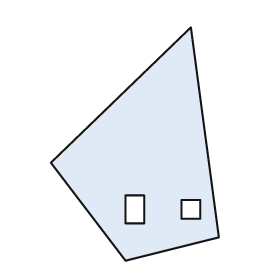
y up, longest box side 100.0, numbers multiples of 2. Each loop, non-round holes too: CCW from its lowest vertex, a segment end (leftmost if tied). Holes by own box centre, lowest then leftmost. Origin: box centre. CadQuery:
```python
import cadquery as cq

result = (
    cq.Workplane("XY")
    .moveTo(-4.0, -50.0)
    .lineTo(36.0, -40.0)
    .lineTo(24.0, 50.0)
    .lineTo(-36.0, -8.0)
    .close()
    .moveTo(-4.0, -34.0)
    .lineTo(4.0, -34.0)
    .lineTo(4.0, -22.0)
    .lineTo(-4.0, -22.0)
    .close()
    .moveTo(20.0, -32.0)
    .lineTo(28.0, -32.0)
    .lineTo(28.0, -24.0)
    .lineTo(20.0, -24.0)
    .close()
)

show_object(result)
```